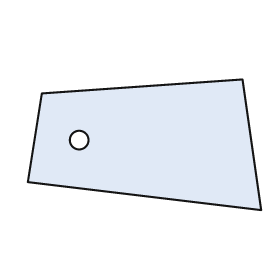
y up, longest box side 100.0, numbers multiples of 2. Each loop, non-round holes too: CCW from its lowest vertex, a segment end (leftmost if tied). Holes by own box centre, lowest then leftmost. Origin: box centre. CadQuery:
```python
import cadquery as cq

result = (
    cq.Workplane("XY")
    .moveTo(50.0, -28.0)
    .lineTo(42.0, 28.0)
    .lineTo(-44.0, 22.0)
    .lineTo(-50.0, -16.0)
    .close()
    .moveTo(-28.0, 2.0)
    .circle(4.0)
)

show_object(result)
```